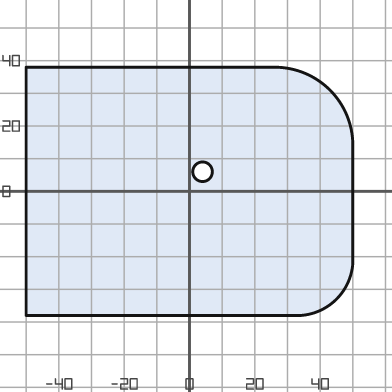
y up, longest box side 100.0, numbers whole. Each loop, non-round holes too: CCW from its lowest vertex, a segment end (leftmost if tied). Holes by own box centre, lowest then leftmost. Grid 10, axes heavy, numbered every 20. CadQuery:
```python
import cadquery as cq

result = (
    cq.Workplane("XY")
    .moveTo(-50.0, -38.0)
    .lineTo(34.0, -38.0)
    .threePointArc((45.0, -33.0), (50.0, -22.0))
    .lineTo(50.0, 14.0)
    .threePointArc((43.0, 31.0), (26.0, 38.0))
    .lineTo(-50.0, 38.0)
    .close()
    .moveTo(4.0, 6.0)
    .circle(3.0)
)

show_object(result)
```